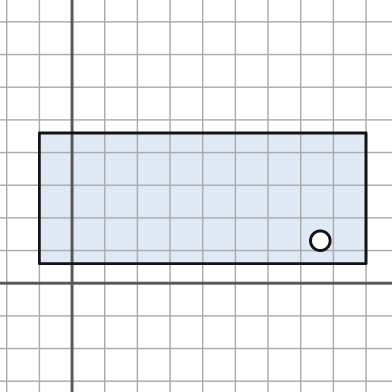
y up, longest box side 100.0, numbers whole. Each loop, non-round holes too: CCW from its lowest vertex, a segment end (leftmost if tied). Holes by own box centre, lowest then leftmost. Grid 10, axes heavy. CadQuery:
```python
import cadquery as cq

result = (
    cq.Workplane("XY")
    .moveTo(-10.0, 6.0)
    .lineTo(90.0, 6.0)
    .lineTo(90.0, 46.0)
    .lineTo(-10.0, 46.0)
    .close()
    .moveTo(76.0, 13.0)
    .circle(3.0)
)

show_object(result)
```